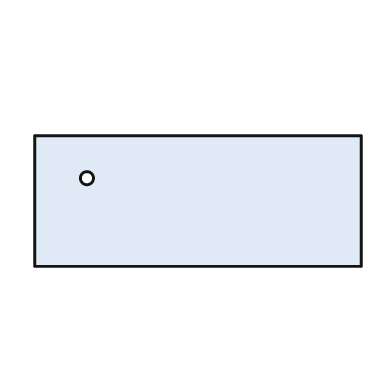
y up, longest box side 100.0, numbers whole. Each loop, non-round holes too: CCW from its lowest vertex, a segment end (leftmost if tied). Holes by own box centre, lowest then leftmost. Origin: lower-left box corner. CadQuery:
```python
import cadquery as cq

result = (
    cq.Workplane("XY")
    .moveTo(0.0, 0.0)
    .lineTo(100.0, 0.0)
    .lineTo(100.0, 40.0)
    .lineTo(0.0, 40.0)
    .close()
    .moveTo(16.0, 27.0)
    .circle(2.0)
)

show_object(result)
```